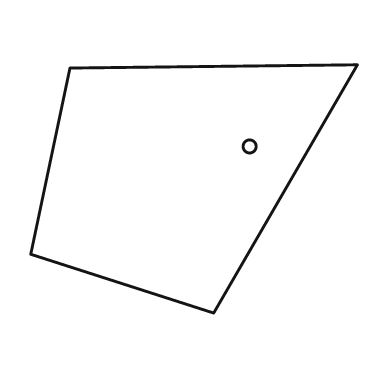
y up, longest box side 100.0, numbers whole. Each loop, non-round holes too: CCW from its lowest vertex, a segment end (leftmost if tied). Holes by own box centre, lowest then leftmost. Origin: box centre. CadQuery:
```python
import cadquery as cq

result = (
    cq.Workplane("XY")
    .moveTo(6.0, -38.0)
    .lineTo(50.0, 38.0)
    .lineTo(-38.0, 37.0)
    .lineTo(-50.0, -20.0)
    .close()
    .moveTo(17.0, 13.0)
    .circle(2.0)
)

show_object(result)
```